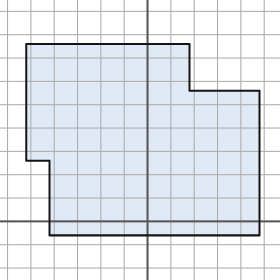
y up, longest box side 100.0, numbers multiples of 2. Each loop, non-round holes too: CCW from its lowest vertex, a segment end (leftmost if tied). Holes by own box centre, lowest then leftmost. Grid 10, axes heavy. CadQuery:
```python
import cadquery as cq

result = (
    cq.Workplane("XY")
    .moveTo(-42.0, -6.0)
    .lineTo(48.0, -6.0)
    .lineTo(48.0, 56.0)
    .lineTo(18.0, 56.0)
    .lineTo(18.0, 76.0)
    .lineTo(-52.0, 76.0)
    .lineTo(-52.0, 26.0)
    .lineTo(-42.0, 26.0)
    .close()
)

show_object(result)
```